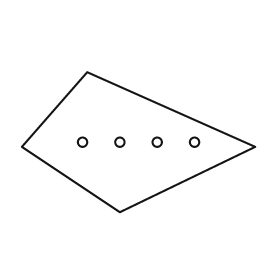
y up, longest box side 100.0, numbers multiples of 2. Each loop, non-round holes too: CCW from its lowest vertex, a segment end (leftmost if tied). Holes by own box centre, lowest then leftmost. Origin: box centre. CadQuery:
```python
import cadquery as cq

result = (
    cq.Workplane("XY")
    .moveTo(-8.0, -30.0)
    .lineTo(50.0, -2.0)
    .lineTo(-22.0, 30.0)
    .lineTo(-50.0, -2.0)
    .close()
    .moveTo(-24.0, 0.0)
    .circle(2.0)
    .moveTo(-8.0, 0.0)
    .circle(2.0)
    .moveTo(8.0, 0.0)
    .circle(2.0)
    .moveTo(24.0, 0.0)
    .circle(2.0)
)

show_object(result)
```